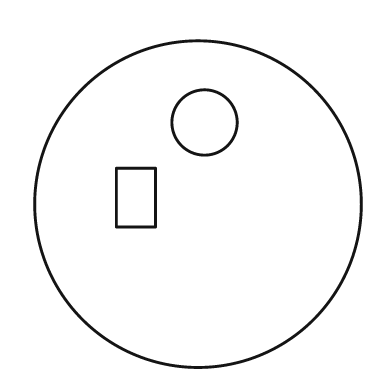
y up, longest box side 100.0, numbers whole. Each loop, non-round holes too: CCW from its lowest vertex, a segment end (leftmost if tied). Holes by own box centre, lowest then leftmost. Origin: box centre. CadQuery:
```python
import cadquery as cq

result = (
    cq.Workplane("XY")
    .moveTo(0.0, 0.0)
    .circle(50.0)
    .moveTo(-25.0, -7.0)
    .lineTo(-13.0, -7.0)
    .lineTo(-13.0, 11.0)
    .lineTo(-25.0, 11.0)
    .close()
    .moveTo(2.0, 25.0)
    .circle(10.0)
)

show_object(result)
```